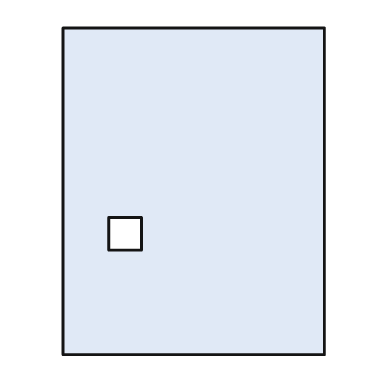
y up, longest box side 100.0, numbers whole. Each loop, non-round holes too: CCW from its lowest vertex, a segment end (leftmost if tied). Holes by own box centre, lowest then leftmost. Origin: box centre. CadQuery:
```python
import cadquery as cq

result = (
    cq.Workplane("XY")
    .moveTo(-40.0, -50.0)
    .lineTo(40.0, -50.0)
    .lineTo(40.0, 50.0)
    .lineTo(-40.0, 50.0)
    .close()
    .moveTo(-26.0, -18.0)
    .lineTo(-16.0, -18.0)
    .lineTo(-16.0, -8.0)
    .lineTo(-26.0, -8.0)
    .close()
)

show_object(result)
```